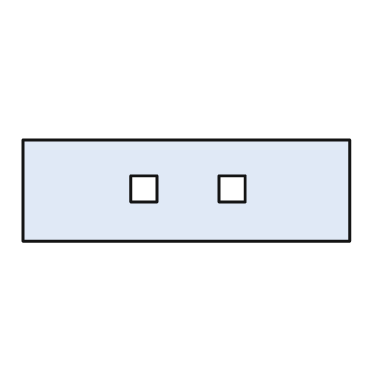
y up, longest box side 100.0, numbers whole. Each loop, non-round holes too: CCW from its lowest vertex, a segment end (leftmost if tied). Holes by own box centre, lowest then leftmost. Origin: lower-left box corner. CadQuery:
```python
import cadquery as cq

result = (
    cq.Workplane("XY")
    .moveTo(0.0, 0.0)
    .lineTo(100.0, 0.0)
    .lineTo(100.0, 31.0)
    .lineTo(0.0, 31.0)
    .close()
    .moveTo(33.0, 12.0)
    .lineTo(41.0, 12.0)
    .lineTo(41.0, 20.0)
    .lineTo(33.0, 20.0)
    .close()
    .moveTo(60.0, 12.0)
    .lineTo(68.0, 12.0)
    .lineTo(68.0, 20.0)
    .lineTo(60.0, 20.0)
    .close()
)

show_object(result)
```